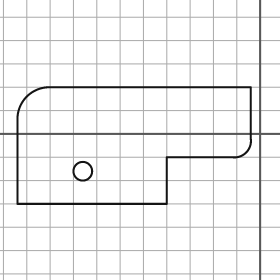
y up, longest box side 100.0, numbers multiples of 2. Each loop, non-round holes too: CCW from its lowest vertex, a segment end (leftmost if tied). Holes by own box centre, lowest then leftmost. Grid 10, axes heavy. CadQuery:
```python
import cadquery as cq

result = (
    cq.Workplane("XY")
    .moveTo(-104.0, -30.0)
    .lineTo(-40.0, -30.0)
    .lineTo(-40.0, -10.0)
    .lineTo(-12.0, -10.0)
    .threePointArc((-6.0, -8.0), (-4.0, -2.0))
    .lineTo(-4.0, 20.0)
    .lineTo(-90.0, 20.0)
    .threePointArc((-100.0, 16.0), (-104.0, 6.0))
    .close()
    .moveTo(-76.0, -16.0)
    .circle(4.0)
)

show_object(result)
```